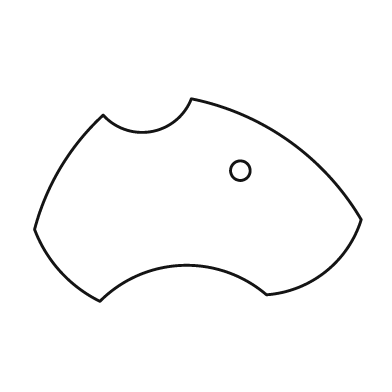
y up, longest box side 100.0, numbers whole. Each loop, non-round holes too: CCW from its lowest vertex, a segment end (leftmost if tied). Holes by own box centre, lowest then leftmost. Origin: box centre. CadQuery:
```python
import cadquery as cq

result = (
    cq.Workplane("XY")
    .moveTo(-30.0, -31.0)
    .threePointArc((-5.0, -20.0), (21.0, -29.0))
    .threePointArc((39.0, -22.0), (50.0, -6.0))
    .threePointArc((28.0, 18.0), (-2.0, 31.0))
    .threePointArc((-14.0, 21.0), (-29.0, 26.0))
    .threePointArc((-42.0, 10.0), (-50.0, -9.0))
    .threePointArc((-42.0, -22.0), (-30.0, -31.0))
    .close()
    .moveTo(13.0, 9.0)
    .circle(3.0)
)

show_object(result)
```